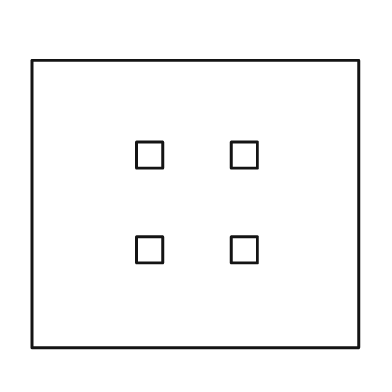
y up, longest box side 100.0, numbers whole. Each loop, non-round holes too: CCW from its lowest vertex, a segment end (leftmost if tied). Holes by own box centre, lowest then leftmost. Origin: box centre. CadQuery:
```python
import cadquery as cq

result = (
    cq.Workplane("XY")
    .moveTo(-50.0, -44.0)
    .lineTo(50.0, -44.0)
    .lineTo(50.0, 44.0)
    .lineTo(-50.0, 44.0)
    .close()
    .moveTo(-18.0, -18.0)
    .lineTo(-10.0, -18.0)
    .lineTo(-10.0, -10.0)
    .lineTo(-18.0, -10.0)
    .close()
    .moveTo(11.0, -18.0)
    .lineTo(19.0, -18.0)
    .lineTo(19.0, -10.0)
    .lineTo(11.0, -10.0)
    .close()
    .moveTo(-18.0, 11.0)
    .lineTo(-10.0, 11.0)
    .lineTo(-10.0, 19.0)
    .lineTo(-18.0, 19.0)
    .close()
    .moveTo(11.0, 11.0)
    .lineTo(19.0, 11.0)
    .lineTo(19.0, 19.0)
    .lineTo(11.0, 19.0)
    .close()
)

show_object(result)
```